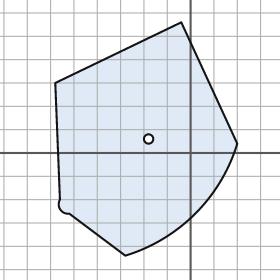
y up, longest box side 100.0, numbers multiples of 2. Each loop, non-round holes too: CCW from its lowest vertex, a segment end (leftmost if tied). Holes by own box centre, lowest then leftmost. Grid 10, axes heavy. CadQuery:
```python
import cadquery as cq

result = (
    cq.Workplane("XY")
    .moveTo(-28.0, -44.0)
    .threePointArc((2.0, -26.0), (20.0, 4.0))
    .lineTo(-4.0, 56.0)
    .lineTo(-58.0, 30.0)
    .lineTo(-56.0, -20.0)
    .threePointArc((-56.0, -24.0), (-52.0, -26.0))
    .close()
    .moveTo(-18.0, 6.0)
    .circle(2.0)
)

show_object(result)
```